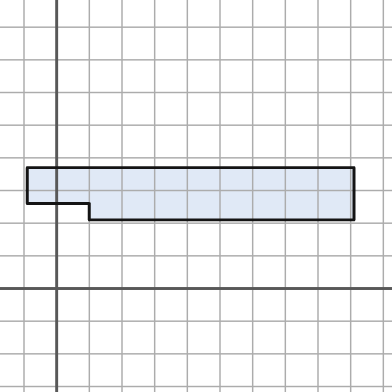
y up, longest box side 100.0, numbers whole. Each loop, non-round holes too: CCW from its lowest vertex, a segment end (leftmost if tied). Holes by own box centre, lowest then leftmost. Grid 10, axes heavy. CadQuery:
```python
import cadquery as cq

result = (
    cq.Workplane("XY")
    .moveTo(10.0, 21.0)
    .lineTo(91.0, 21.0)
    .lineTo(91.0, 37.0)
    .lineTo(-9.0, 37.0)
    .lineTo(-9.0, 26.0)
    .lineTo(10.0, 26.0)
    .close()
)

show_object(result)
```